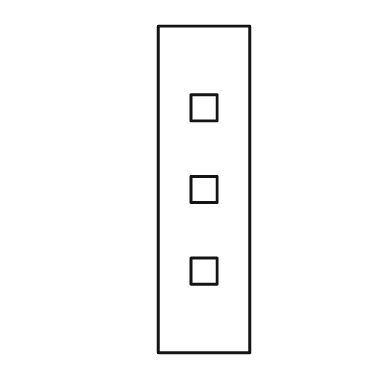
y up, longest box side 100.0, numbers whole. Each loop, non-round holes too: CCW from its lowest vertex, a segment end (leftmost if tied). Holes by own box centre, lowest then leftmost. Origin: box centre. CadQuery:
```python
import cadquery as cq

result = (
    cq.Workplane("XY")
    .moveTo(-14.0, -50.0)
    .lineTo(14.0, -50.0)
    .lineTo(14.0, 50.0)
    .lineTo(-14.0, 50.0)
    .close()
    .moveTo(-4.0, -29.0)
    .lineTo(4.0, -29.0)
    .lineTo(4.0, -21.0)
    .lineTo(-4.0, -21.0)
    .close()
    .moveTo(-4.0, -4.0)
    .lineTo(4.0, -4.0)
    .lineTo(4.0, 4.0)
    .lineTo(-4.0, 4.0)
    .close()
    .moveTo(-4.0, 21.0)
    .lineTo(4.0, 21.0)
    .lineTo(4.0, 29.0)
    .lineTo(-4.0, 29.0)
    .close()
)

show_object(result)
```